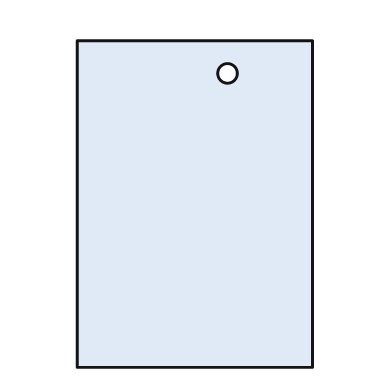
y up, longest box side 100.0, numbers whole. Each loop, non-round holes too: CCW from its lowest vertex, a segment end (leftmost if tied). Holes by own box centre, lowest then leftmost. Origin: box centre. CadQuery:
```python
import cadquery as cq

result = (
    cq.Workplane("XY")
    .moveTo(-36.0, -50.0)
    .lineTo(36.0, -50.0)
    .lineTo(36.0, 50.0)
    .lineTo(-36.0, 50.0)
    .close()
    .moveTo(10.0, 40.0)
    .circle(3.0)
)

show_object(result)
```